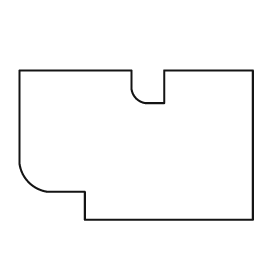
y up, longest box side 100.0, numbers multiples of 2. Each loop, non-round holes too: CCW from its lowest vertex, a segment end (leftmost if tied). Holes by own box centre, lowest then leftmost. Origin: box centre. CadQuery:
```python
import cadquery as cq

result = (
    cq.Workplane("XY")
    .moveTo(-22.0, -32.0)
    .lineTo(50.0, -32.0)
    .lineTo(50.0, 32.0)
    .lineTo(12.0, 32.0)
    .lineTo(12.0, 18.0)
    .lineTo(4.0, 18.0)
    .threePointArc((0.0, 20.0), (-2.0, 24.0))
    .lineTo(-2.0, 32.0)
    .lineTo(-50.0, 32.0)
    .lineTo(-50.0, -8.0)
    .threePointArc((-46.0, -16.0), (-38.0, -20.0))
    .lineTo(-22.0, -20.0)
    .close()
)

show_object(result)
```